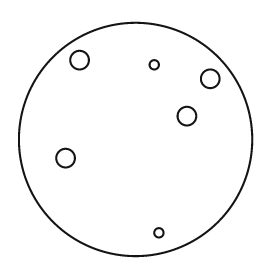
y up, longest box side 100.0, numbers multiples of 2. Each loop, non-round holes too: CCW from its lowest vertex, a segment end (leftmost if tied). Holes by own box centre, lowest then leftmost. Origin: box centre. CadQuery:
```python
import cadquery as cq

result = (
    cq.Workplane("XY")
    .moveTo(0.0, 0.0)
    .circle(50.0)
    .moveTo(10.0, -40.0)
    .circle(2.0)
    .moveTo(-30.0, -8.0)
    .circle(4.0)
    .moveTo(22.0, 10.0)
    .circle(4.0)
    .moveTo(32.0, 26.0)
    .circle(4.0)
    .moveTo(8.0, 32.0)
    .circle(2.0)
    .moveTo(-24.0, 34.0)
    .circle(4.0)
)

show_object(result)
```